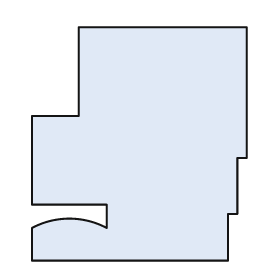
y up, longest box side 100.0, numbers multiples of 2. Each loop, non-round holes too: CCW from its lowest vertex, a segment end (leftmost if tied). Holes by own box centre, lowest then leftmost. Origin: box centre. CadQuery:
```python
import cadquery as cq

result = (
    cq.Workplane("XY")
    .moveTo(-46.0, -50.0)
    .lineTo(38.0, -50.0)
    .lineTo(38.0, -30.0)
    .lineTo(42.0, -30.0)
    .lineTo(42.0, -6.0)
    .lineTo(46.0, -6.0)
    .lineTo(46.0, 50.0)
    .lineTo(-26.0, 50.0)
    .lineTo(-26.0, 12.0)
    .lineTo(-46.0, 12.0)
    .lineTo(-46.0, -26.0)
    .lineTo(-14.0, -26.0)
    .lineTo(-14.0, -36.0)
    .threePointArc((-30.0, -32.0), (-46.0, -36.0))
    .close()
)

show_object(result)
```